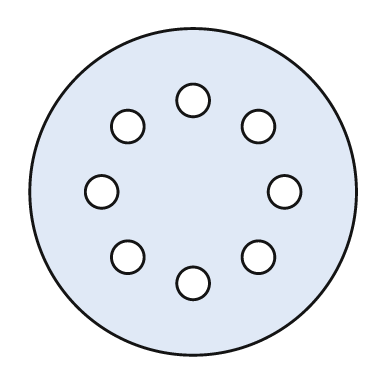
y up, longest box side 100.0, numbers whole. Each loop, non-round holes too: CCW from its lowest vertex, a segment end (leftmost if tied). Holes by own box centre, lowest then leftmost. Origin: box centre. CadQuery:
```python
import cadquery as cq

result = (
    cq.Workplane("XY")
    .moveTo(0.0, 0.0)
    .circle(50.0)
    .moveTo(0.0, -28.0)
    .circle(5.0)
    .moveTo(-20.0, -20.0)
    .circle(5.0)
    .moveTo(20.0, -20.0)
    .circle(5.0)
    .moveTo(-28.0, 0.0)
    .circle(5.0)
    .moveTo(28.0, 0.0)
    .circle(5.0)
    .moveTo(-20.0, 20.0)
    .circle(5.0)
    .moveTo(20.0, 20.0)
    .circle(5.0)
    .moveTo(0.0, 28.0)
    .circle(5.0)
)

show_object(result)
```